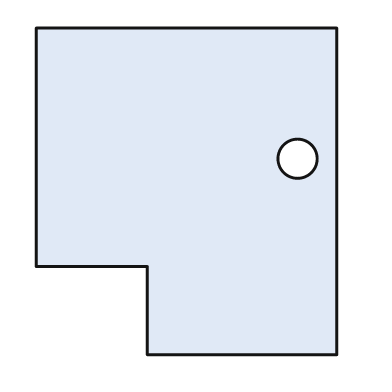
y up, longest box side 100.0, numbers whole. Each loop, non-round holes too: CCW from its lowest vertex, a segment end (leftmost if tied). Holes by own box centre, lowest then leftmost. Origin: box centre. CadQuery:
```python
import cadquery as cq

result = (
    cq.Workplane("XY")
    .moveTo(-12.0, -50.0)
    .lineTo(46.0, -50.0)
    .lineTo(46.0, 50.0)
    .lineTo(-46.0, 50.0)
    .lineTo(-46.0, -23.0)
    .lineTo(-12.0, -23.0)
    .close()
    .moveTo(34.0, 10.0)
    .circle(6.0)
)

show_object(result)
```